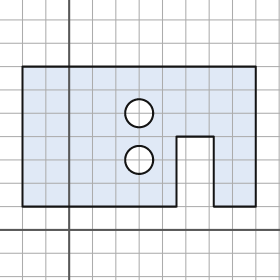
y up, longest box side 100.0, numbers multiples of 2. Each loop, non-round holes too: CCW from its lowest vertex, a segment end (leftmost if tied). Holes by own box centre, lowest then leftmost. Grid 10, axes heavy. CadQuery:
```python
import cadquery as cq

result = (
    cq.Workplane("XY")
    .moveTo(-20.0, 10.0)
    .lineTo(46.0, 10.0)
    .lineTo(46.0, 40.0)
    .lineTo(62.0, 40.0)
    .lineTo(62.0, 10.0)
    .lineTo(80.0, 10.0)
    .lineTo(80.0, 70.0)
    .lineTo(-20.0, 70.0)
    .close()
    .moveTo(30.0, 30.0)
    .circle(6.0)
    .moveTo(30.0, 50.0)
    .circle(6.0)
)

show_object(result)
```